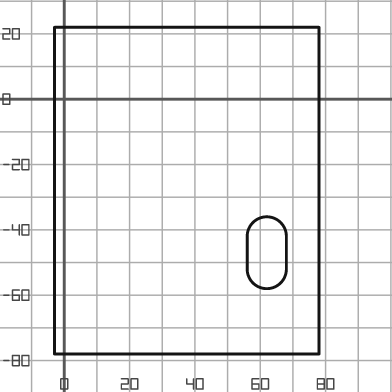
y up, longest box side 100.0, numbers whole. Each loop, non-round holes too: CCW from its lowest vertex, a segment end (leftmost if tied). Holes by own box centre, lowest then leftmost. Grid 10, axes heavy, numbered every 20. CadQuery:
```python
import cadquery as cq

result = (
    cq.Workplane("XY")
    .moveTo(-3.0, -78.0)
    .lineTo(78.0, -78.0)
    .lineTo(78.0, 22.0)
    .lineTo(-3.0, 22.0)
    .close()
    .moveTo(56.0, -52.0)
    .threePointArc((62.0, -58.0), (68.0, -52.0))
    .lineTo(68.0, -42.0)
    .threePointArc((62.0, -36.0), (56.0, -42.0))
    .close()
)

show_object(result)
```